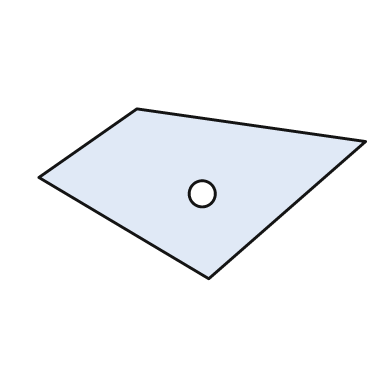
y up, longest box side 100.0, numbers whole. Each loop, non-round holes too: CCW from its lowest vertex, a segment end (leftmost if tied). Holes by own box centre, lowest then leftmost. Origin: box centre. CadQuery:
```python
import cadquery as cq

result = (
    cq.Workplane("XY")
    .moveTo(2.0, -26.0)
    .lineTo(50.0, 16.0)
    .lineTo(-20.0, 26.0)
    .lineTo(-50.0, 5.0)
    .close()
    .moveTo(0.0, 0.0)
    .circle(4.0)
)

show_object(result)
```